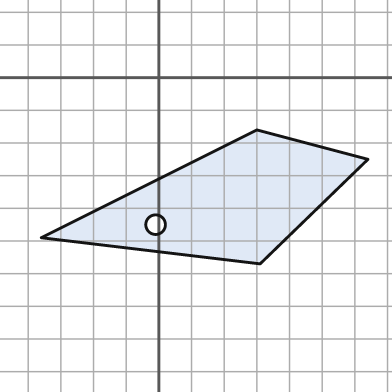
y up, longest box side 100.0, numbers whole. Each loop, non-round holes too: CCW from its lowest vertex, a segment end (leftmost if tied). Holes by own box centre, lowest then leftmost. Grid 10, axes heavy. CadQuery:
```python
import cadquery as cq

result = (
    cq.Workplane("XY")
    .moveTo(31.0, -57.0)
    .lineTo(64.0, -25.0)
    .lineTo(30.0, -16.0)
    .lineTo(-36.0, -49.0)
    .close()
    .moveTo(-1.0, -45.0)
    .circle(3.0)
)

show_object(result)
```